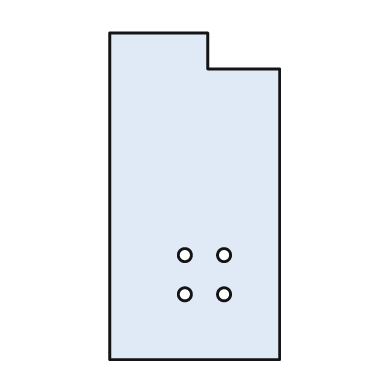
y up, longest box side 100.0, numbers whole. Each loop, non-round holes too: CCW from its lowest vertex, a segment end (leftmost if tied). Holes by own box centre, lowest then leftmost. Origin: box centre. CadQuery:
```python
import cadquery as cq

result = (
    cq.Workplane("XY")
    .moveTo(-26.0, -50.0)
    .lineTo(26.0, -50.0)
    .lineTo(26.0, 39.0)
    .lineTo(4.0, 39.0)
    .lineTo(4.0, 50.0)
    .lineTo(-26.0, 50.0)
    .close()
    .moveTo(-3.0, -30.0)
    .circle(2.0)
    .moveTo(9.0, -30.0)
    .circle(2.0)
    .moveTo(-3.0, -18.0)
    .circle(2.0)
    .moveTo(9.0, -18.0)
    .circle(2.0)
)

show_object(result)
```